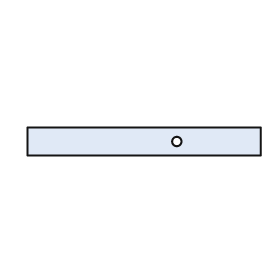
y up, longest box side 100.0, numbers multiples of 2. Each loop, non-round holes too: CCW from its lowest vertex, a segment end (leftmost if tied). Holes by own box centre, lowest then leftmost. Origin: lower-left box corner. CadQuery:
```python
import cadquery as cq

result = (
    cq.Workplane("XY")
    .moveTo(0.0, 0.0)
    .lineTo(100.0, 0.0)
    .lineTo(100.0, 12.0)
    .lineTo(0.0, 12.0)
    .close()
    .moveTo(64.0, 6.0)
    .circle(2.0)
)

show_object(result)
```